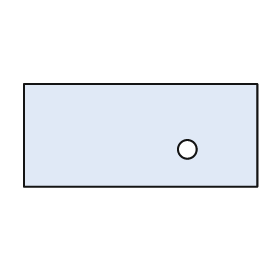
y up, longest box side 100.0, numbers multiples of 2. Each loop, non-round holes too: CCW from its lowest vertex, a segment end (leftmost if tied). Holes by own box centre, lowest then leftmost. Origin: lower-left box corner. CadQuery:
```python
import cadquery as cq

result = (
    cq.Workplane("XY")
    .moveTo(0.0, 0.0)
    .lineTo(100.0, 0.0)
    .lineTo(100.0, 44.0)
    .lineTo(0.0, 44.0)
    .close()
    .moveTo(70.0, 16.0)
    .circle(4.0)
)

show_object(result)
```